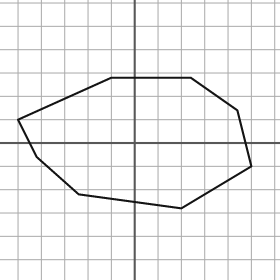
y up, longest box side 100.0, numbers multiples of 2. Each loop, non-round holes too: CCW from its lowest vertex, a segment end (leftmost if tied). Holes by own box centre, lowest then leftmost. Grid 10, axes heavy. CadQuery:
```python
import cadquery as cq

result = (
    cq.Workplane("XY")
    .moveTo(20.0, -28.0)
    .lineTo(50.0, -10.0)
    .lineTo(44.0, 14.0)
    .lineTo(24.0, 28.0)
    .lineTo(-10.0, 28.0)
    .lineTo(-50.0, 10.0)
    .lineTo(-42.0, -6.0)
    .lineTo(-24.0, -22.0)
    .close()
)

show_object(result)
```